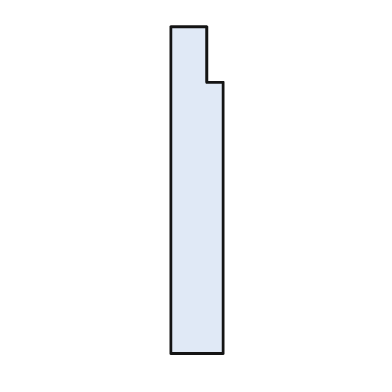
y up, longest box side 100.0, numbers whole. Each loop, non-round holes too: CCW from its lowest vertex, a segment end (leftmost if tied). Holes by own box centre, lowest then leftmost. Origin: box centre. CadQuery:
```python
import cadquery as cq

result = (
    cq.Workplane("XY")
    .moveTo(-8.0, -50.0)
    .lineTo(8.0, -50.0)
    .lineTo(8.0, 33.0)
    .lineTo(3.0, 33.0)
    .lineTo(3.0, 50.0)
    .lineTo(-8.0, 50.0)
    .close()
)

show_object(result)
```